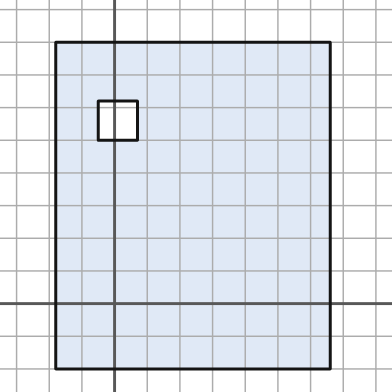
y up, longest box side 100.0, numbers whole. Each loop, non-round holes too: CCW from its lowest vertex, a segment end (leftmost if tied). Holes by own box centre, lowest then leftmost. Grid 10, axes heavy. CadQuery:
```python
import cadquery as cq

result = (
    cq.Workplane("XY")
    .moveTo(-18.0, -20.0)
    .lineTo(66.0, -20.0)
    .lineTo(66.0, 80.0)
    .lineTo(-18.0, 80.0)
    .close()
    .moveTo(-5.0, 50.0)
    .lineTo(7.0, 50.0)
    .lineTo(7.0, 62.0)
    .lineTo(-5.0, 62.0)
    .close()
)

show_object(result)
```